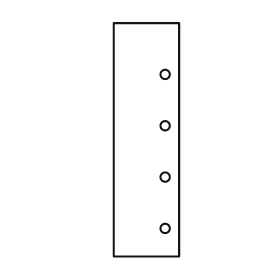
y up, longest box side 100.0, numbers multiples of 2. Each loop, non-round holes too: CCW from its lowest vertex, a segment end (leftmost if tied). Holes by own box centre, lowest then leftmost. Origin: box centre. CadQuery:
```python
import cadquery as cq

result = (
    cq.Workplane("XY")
    .moveTo(-14.0, -50.0)
    .lineTo(14.0, -50.0)
    .lineTo(14.0, 50.0)
    .lineTo(-14.0, 50.0)
    .close()
    .moveTo(8.0, -38.0)
    .circle(2.0)
    .moveTo(8.0, -16.0)
    .circle(2.0)
    .moveTo(8.0, 6.0)
    .circle(2.0)
    .moveTo(8.0, 28.0)
    .circle(2.0)
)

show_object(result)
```